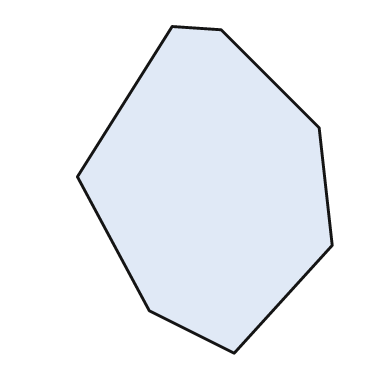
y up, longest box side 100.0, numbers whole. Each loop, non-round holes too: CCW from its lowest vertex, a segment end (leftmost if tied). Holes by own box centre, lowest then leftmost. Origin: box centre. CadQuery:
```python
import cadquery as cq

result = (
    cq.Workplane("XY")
    .moveTo(9.0, -50.0)
    .lineTo(39.0, -17.0)
    .lineTo(35.0, 19.0)
    .lineTo(5.0, 49.0)
    .lineTo(-10.0, 50.0)
    .lineTo(-39.0, 4.0)
    .lineTo(-17.0, -37.0)
    .close()
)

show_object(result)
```